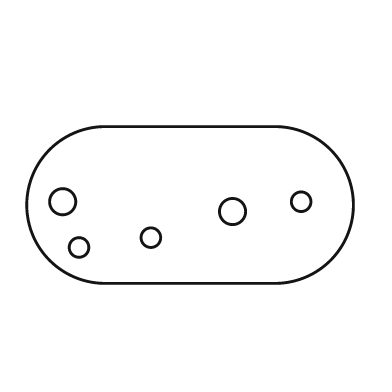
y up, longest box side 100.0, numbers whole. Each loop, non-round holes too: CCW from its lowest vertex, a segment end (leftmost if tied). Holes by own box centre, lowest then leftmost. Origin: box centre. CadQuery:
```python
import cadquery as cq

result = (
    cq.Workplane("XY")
    .moveTo(-26.0, -24.0)
    .lineTo(26.0, -24.0)
    .threePointArc((50.0, 0.0), (26.0, 24.0))
    .lineTo(-26.0, 24.0)
    .threePointArc((-50.0, 0.0), (-26.0, -24.0))
    .close()
    .moveTo(-34.0, -13.0)
    .circle(3.0)
    .moveTo(-12.0, -10.0)
    .circle(3.0)
    .moveTo(13.0, -2.0)
    .circle(4.0)
    .moveTo(-39.0, 1.0)
    .circle(4.0)
    .moveTo(34.0, 1.0)
    .circle(3.0)
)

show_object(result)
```